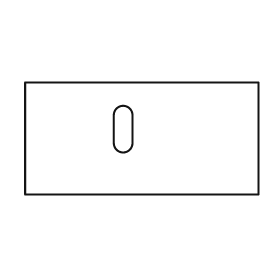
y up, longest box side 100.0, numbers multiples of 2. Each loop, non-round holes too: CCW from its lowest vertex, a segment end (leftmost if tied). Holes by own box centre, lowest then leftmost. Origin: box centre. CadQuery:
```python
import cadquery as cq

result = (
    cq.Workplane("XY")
    .moveTo(-50.0, -24.0)
    .lineTo(50.0, -24.0)
    .lineTo(50.0, 24.0)
    .lineTo(-50.0, 24.0)
    .close()
    .moveTo(-12.0, -2.0)
    .threePointArc((-8.0, -6.0), (-4.0, -2.0))
    .lineTo(-4.0, 10.0)
    .threePointArc((-8.0, 14.0), (-12.0, 10.0))
    .close()
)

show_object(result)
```